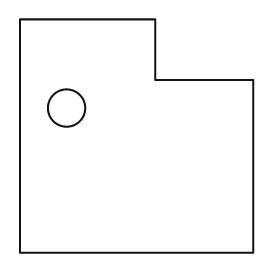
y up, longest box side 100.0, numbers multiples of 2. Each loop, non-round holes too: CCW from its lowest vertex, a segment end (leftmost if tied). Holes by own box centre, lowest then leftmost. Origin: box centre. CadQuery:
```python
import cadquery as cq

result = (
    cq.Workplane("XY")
    .moveTo(-50.0, -50.0)
    .lineTo(50.0, -50.0)
    .lineTo(50.0, 24.0)
    .lineTo(8.0, 24.0)
    .lineTo(8.0, 50.0)
    .lineTo(-50.0, 50.0)
    .close()
    .moveTo(-30.0, 12.0)
    .circle(8.0)
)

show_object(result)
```